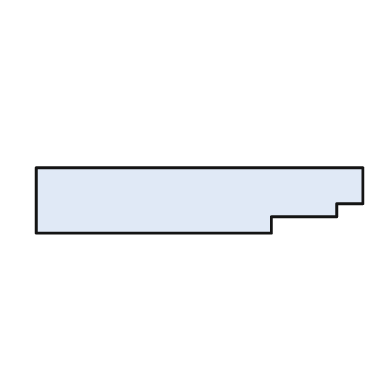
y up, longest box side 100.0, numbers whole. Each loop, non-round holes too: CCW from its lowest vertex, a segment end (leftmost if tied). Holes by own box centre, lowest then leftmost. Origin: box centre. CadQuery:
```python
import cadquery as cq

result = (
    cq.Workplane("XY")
    .moveTo(-50.0, -10.0)
    .lineTo(22.0, -10.0)
    .lineTo(22.0, -5.0)
    .lineTo(42.0, -5.0)
    .lineTo(42.0, -1.0)
    .lineTo(50.0, -1.0)
    .lineTo(50.0, 10.0)
    .lineTo(-50.0, 10.0)
    .close()
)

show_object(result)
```